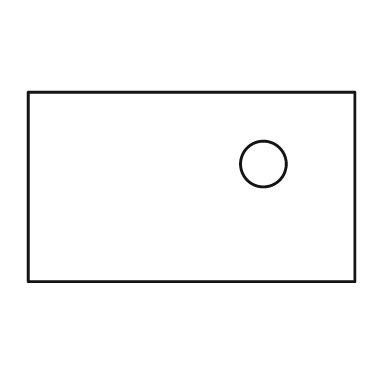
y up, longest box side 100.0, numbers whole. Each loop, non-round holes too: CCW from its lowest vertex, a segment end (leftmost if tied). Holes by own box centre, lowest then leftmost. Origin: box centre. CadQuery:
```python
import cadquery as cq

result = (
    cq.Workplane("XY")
    .moveTo(-50.0, -29.0)
    .lineTo(50.0, -29.0)
    .lineTo(50.0, 29.0)
    .lineTo(-50.0, 29.0)
    .close()
    .moveTo(22.0, 7.0)
    .circle(7.0)
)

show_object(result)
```